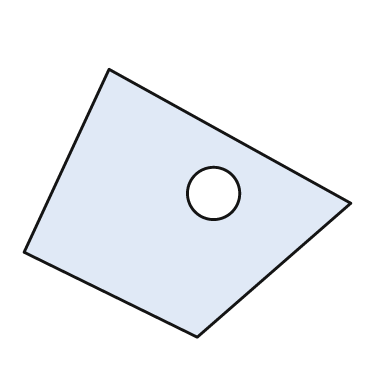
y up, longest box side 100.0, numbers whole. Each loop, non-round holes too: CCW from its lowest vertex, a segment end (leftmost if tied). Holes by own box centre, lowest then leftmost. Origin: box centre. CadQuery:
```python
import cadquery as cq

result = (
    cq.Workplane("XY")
    .moveTo(3.0, -41.0)
    .lineTo(50.0, 0.0)
    .lineTo(-24.0, 41.0)
    .lineTo(-50.0, -15.0)
    .close()
    .moveTo(8.0, 3.0)
    .circle(8.0)
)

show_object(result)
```